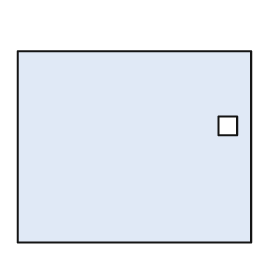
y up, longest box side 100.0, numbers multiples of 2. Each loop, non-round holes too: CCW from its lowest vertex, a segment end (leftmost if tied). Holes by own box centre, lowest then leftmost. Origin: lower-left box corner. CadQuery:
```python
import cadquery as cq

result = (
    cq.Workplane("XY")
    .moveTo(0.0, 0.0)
    .lineTo(100.0, 0.0)
    .lineTo(100.0, 82.0)
    .lineTo(0.0, 82.0)
    .close()
    .moveTo(86.0, 46.0)
    .lineTo(94.0, 46.0)
    .lineTo(94.0, 54.0)
    .lineTo(86.0, 54.0)
    .close()
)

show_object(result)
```